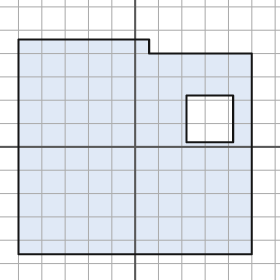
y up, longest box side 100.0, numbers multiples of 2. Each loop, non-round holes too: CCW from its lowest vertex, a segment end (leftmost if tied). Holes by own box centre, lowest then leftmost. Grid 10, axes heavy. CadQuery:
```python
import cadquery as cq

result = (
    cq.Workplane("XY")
    .moveTo(-50.0, -46.0)
    .lineTo(50.0, -46.0)
    .lineTo(50.0, 40.0)
    .lineTo(6.0, 40.0)
    .lineTo(6.0, 46.0)
    .lineTo(-50.0, 46.0)
    .close()
    .moveTo(22.0, 2.0)
    .lineTo(42.0, 2.0)
    .lineTo(42.0, 22.0)
    .lineTo(22.0, 22.0)
    .close()
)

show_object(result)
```